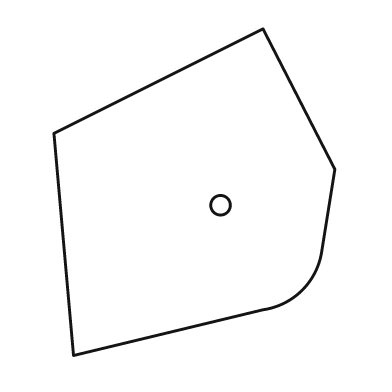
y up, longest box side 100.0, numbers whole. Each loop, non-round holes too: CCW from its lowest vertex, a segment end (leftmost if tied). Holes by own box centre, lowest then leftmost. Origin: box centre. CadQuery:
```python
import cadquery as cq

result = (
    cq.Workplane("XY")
    .moveTo(-37.0, -50.0)
    .lineTo(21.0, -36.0)
    .threePointArc((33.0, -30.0), (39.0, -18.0))
    .lineTo(43.0, 7.0)
    .lineTo(21.0, 50.0)
    .lineTo(-43.0, 18.0)
    .close()
    .moveTo(8.0, -4.0)
    .circle(3.0)
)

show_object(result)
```